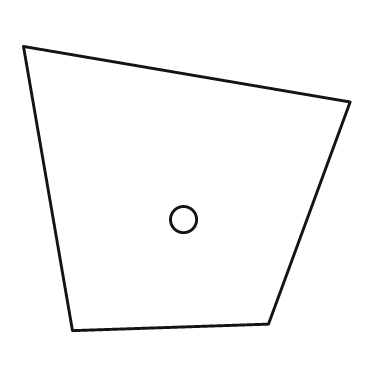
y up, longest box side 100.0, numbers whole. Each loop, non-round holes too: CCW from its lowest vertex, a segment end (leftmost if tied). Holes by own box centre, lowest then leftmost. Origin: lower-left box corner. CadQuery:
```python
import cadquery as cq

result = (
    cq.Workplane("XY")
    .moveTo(15.0, 0.0)
    .lineTo(75.0, 2.0)
    .lineTo(100.0, 70.0)
    .lineTo(0.0, 87.0)
    .close()
    .moveTo(49.0, 34.0)
    .circle(4.0)
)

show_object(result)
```